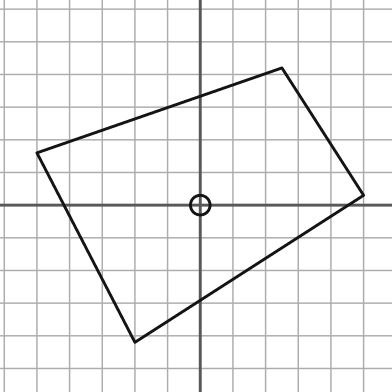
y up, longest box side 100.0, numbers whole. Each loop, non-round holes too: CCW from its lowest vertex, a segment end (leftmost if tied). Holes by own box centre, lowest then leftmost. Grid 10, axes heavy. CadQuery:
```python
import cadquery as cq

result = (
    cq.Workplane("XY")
    .moveTo(-20.0, -42.0)
    .lineTo(50.0, 3.0)
    .lineTo(25.0, 42.0)
    .lineTo(-50.0, 16.0)
    .close()
    .moveTo(0.0, 0.0)
    .circle(3.0)
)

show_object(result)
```